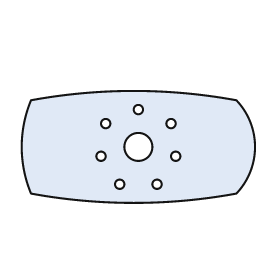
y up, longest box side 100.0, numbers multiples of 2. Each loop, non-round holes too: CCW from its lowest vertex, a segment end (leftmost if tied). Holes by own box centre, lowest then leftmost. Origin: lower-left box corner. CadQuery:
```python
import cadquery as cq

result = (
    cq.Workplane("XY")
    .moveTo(4.0, 4.0)
    .threePointArc((48.0, 0.0), (92.0, 4.0))
    .threePointArc((100.0, 24.0), (92.0, 44.0))
    .threePointArc((48.0, 48.0), (4.0, 44.0))
    .threePointArc((0.0, 24.0), (4.0, 4.0))
    .close()
    .moveTo(42.0, 8.0)
    .circle(2.0)
    .moveTo(58.0, 8.0)
    .circle(2.0)
    .moveTo(34.0, 20.0)
    .circle(2.0)
    .moveTo(66.0, 20.0)
    .circle(2.0)
    .moveTo(50.0, 24.0)
    .circle(6.0)
    .moveTo(36.0, 34.0)
    .circle(2.0)
    .moveTo(64.0, 34.0)
    .circle(2.0)
    .moveTo(50.0, 40.0)
    .circle(2.0)
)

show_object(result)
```